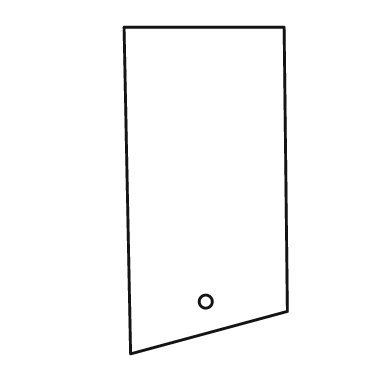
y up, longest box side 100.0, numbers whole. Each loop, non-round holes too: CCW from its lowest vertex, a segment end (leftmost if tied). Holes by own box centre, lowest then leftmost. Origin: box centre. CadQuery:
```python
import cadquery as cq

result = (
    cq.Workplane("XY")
    .moveTo(-23.0, -50.0)
    .lineTo(25.0, -37.0)
    .lineTo(24.0, 50.0)
    .lineTo(-25.0, 50.0)
    .close()
    .moveTo(0.0, -34.0)
    .circle(2.0)
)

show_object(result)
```